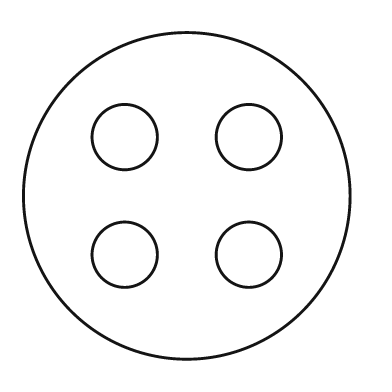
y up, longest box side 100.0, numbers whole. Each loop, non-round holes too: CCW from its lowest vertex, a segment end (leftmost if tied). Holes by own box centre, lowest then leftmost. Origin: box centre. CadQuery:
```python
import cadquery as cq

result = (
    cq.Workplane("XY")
    .moveTo(0.0, 0.0)
    .circle(50.0)
    .moveTo(-19.0, -18.0)
    .circle(10.0)
    .moveTo(19.0, -18.0)
    .circle(10.0)
    .moveTo(-19.0, 18.0)
    .circle(10.0)
    .moveTo(19.0, 18.0)
    .circle(10.0)
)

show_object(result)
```